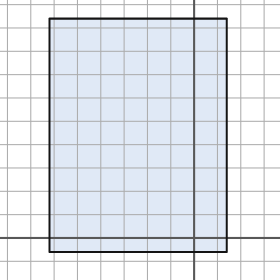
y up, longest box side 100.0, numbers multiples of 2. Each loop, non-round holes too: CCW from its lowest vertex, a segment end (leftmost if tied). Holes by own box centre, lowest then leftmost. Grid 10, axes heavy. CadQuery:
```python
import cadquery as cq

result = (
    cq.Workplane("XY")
    .moveTo(-62.0, -6.0)
    .lineTo(14.0, -6.0)
    .lineTo(14.0, 94.0)
    .lineTo(-62.0, 94.0)
    .close()
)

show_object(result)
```